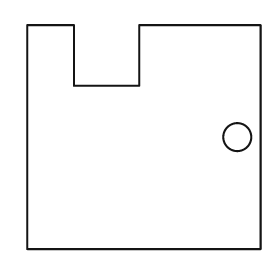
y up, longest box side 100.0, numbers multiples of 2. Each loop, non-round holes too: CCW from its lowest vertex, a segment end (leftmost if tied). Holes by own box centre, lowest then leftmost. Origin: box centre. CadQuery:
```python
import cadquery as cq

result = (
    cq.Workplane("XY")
    .moveTo(-50.0, -48.0)
    .lineTo(50.0, -48.0)
    .lineTo(50.0, 48.0)
    .lineTo(-2.0, 48.0)
    .lineTo(-2.0, 22.0)
    .lineTo(-30.0, 22.0)
    .lineTo(-30.0, 48.0)
    .lineTo(-50.0, 48.0)
    .close()
    .moveTo(40.0, 0.0)
    .circle(6.0)
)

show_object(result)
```